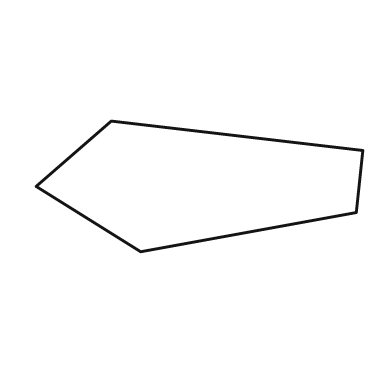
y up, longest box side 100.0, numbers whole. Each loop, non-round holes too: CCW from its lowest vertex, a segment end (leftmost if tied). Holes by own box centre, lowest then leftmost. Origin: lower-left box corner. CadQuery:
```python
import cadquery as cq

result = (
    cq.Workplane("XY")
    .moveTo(32.0, 0.0)
    .lineTo(98.0, 12.0)
    .lineTo(100.0, 31.0)
    .lineTo(23.0, 40.0)
    .lineTo(0.0, 20.0)
    .close()
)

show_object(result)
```